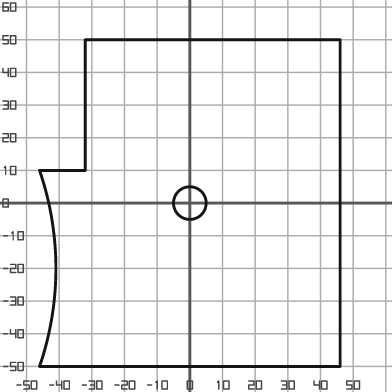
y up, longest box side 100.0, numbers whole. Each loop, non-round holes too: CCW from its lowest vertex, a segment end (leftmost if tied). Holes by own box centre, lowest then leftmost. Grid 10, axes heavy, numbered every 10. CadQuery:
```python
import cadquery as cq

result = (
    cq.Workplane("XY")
    .moveTo(-46.0, -50.0)
    .lineTo(46.0, -50.0)
    .lineTo(46.0, 50.0)
    .lineTo(-32.0, 50.0)
    .lineTo(-32.0, 10.0)
    .lineTo(-46.0, 10.0)
    .threePointArc((-41.0, -20.0), (-46.0, -50.0))
    .close()
    .moveTo(0.0, 0.0)
    .circle(5.0)
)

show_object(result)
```